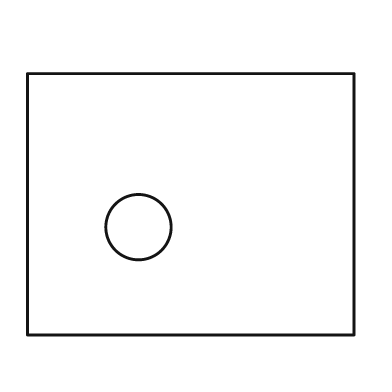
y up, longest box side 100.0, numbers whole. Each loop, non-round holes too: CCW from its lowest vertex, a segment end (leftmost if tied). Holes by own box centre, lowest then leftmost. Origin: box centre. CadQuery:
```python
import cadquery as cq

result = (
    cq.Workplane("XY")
    .moveTo(-50.0, -40.0)
    .lineTo(50.0, -40.0)
    .lineTo(50.0, 40.0)
    .lineTo(-50.0, 40.0)
    .close()
    .moveTo(-16.0, -7.0)
    .circle(10.0)
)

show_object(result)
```